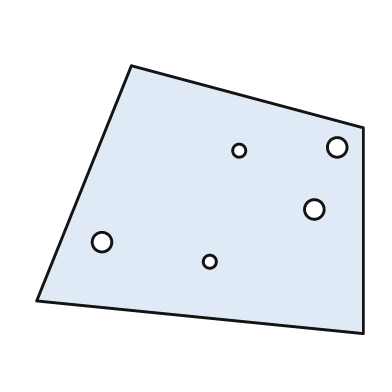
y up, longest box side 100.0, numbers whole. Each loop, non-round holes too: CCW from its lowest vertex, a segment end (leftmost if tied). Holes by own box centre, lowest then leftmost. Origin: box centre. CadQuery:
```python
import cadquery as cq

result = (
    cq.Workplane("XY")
    .moveTo(50.0, -41.0)
    .lineTo(50.0, 22.0)
    .lineTo(-21.0, 41.0)
    .lineTo(-50.0, -31.0)
    .close()
    .moveTo(3.0, -19.0)
    .circle(2.0)
    .moveTo(-30.0, -13.0)
    .circle(3.0)
    .moveTo(35.0, -3.0)
    .circle(3.0)
    .moveTo(12.0, 15.0)
    .circle(2.0)
    .moveTo(42.0, 16.0)
    .circle(3.0)
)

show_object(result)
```